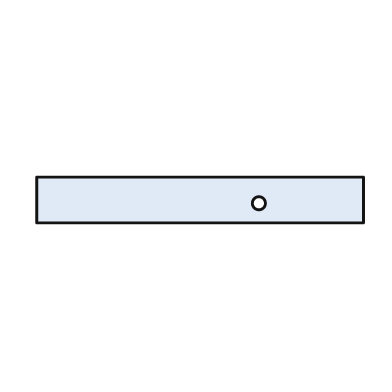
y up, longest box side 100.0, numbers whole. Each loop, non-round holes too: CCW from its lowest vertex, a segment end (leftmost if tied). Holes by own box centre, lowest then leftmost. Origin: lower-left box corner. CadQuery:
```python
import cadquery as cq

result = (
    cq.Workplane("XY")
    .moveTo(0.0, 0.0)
    .lineTo(100.0, 0.0)
    .lineTo(100.0, 14.0)
    .lineTo(0.0, 14.0)
    .close()
    .moveTo(68.0, 6.0)
    .circle(2.0)
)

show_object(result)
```